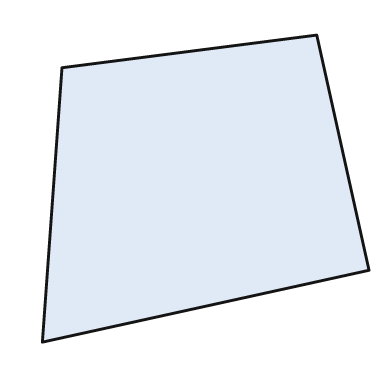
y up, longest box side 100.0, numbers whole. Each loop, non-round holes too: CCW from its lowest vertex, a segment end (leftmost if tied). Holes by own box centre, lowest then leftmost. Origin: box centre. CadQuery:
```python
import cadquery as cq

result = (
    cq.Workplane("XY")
    .moveTo(-50.0, -47.0)
    .lineTo(50.0, -25.0)
    .lineTo(34.0, 47.0)
    .lineTo(-44.0, 37.0)
    .close()
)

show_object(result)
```